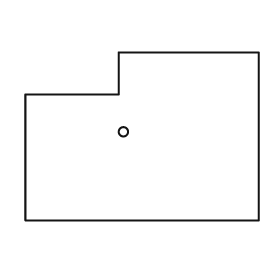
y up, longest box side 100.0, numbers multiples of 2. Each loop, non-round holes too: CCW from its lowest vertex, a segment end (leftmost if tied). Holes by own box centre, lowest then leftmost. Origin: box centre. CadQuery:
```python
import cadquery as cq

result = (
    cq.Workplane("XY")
    .moveTo(-50.0, -36.0)
    .lineTo(50.0, -36.0)
    .lineTo(50.0, 36.0)
    .lineTo(-10.0, 36.0)
    .lineTo(-10.0, 18.0)
    .lineTo(-50.0, 18.0)
    .close()
    .moveTo(-8.0, 2.0)
    .circle(2.0)
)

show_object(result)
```